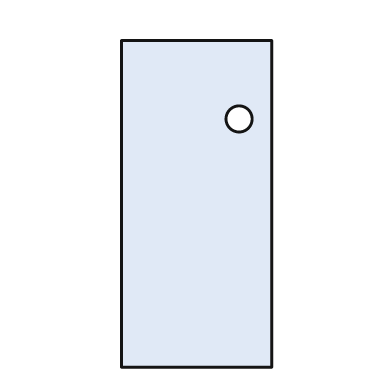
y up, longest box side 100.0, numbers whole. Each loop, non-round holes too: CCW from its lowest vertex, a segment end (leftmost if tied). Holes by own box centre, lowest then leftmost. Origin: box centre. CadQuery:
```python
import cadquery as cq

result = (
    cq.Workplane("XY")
    .moveTo(-23.0, -50.0)
    .lineTo(23.0, -50.0)
    .lineTo(23.0, 50.0)
    .lineTo(-23.0, 50.0)
    .close()
    .moveTo(13.0, 26.0)
    .circle(4.0)
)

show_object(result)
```